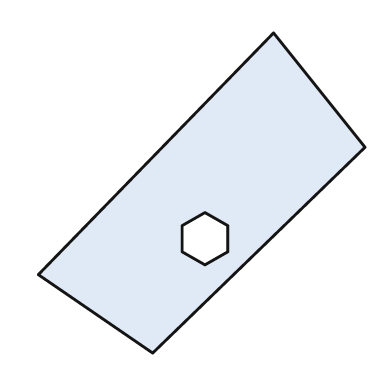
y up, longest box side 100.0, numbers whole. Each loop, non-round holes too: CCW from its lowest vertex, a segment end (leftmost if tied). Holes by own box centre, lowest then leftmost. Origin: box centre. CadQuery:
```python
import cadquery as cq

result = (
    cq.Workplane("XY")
    .moveTo(-15.0, -49.0)
    .lineTo(50.0, 14.0)
    .lineTo(22.0, 49.0)
    .lineTo(-50.0, -25.0)
    .close()
    .moveTo(1.0, -22.0)
    .lineTo(8.0, -18.0)
    .lineTo(8.0, -10.0)
    .lineTo(1.0, -6.0)
    .lineTo(-6.0, -10.0)
    .lineTo(-6.0, -18.0)
    .close()
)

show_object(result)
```